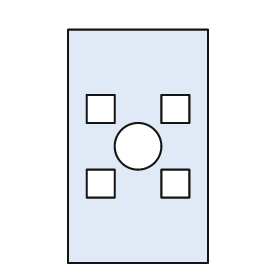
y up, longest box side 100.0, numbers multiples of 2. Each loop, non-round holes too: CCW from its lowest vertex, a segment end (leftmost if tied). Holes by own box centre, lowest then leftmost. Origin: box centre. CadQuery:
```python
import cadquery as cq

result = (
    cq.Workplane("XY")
    .moveTo(-30.0, -50.0)
    .lineTo(30.0, -50.0)
    .lineTo(30.0, 50.0)
    .lineTo(-30.0, 50.0)
    .close()
    .moveTo(-22.0, -22.0)
    .lineTo(-10.0, -22.0)
    .lineTo(-10.0, -10.0)
    .lineTo(-22.0, -10.0)
    .close()
    .moveTo(10.0, -22.0)
    .lineTo(22.0, -22.0)
    .lineTo(22.0, -10.0)
    .lineTo(10.0, -10.0)
    .close()
    .moveTo(0.0, 0.0)
    .circle(10.0)
    .moveTo(-22.0, 10.0)
    .lineTo(-10.0, 10.0)
    .lineTo(-10.0, 22.0)
    .lineTo(-22.0, 22.0)
    .close()
    .moveTo(10.0, 10.0)
    .lineTo(22.0, 10.0)
    .lineTo(22.0, 22.0)
    .lineTo(10.0, 22.0)
    .close()
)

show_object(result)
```